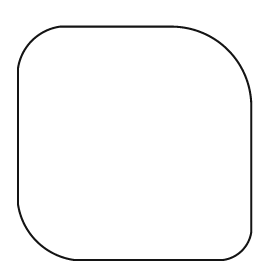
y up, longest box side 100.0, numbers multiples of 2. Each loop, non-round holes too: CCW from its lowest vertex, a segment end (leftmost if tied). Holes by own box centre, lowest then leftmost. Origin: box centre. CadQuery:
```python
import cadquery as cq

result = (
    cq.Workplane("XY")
    .moveTo(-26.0, -50.0)
    .lineTo(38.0, -50.0)
    .threePointArc((46.0, -46.0), (50.0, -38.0))
    .lineTo(50.0, 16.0)
    .threePointArc((40.0, 40.0), (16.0, 50.0))
    .lineTo(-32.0, 50.0)
    .threePointArc((-44.0, 44.0), (-50.0, 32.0))
    .lineTo(-50.0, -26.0)
    .threePointArc((-42.0, -42.0), (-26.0, -50.0))
    .close()
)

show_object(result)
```